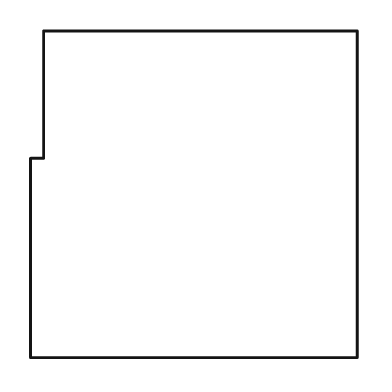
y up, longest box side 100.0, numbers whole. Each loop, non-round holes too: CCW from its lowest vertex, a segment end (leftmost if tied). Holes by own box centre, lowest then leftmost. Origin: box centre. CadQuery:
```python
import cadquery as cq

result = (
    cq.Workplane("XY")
    .moveTo(-50.0, -50.0)
    .lineTo(50.0, -50.0)
    .lineTo(50.0, 50.0)
    .lineTo(-46.0, 50.0)
    .lineTo(-46.0, 11.0)
    .lineTo(-50.0, 11.0)
    .close()
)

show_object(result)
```